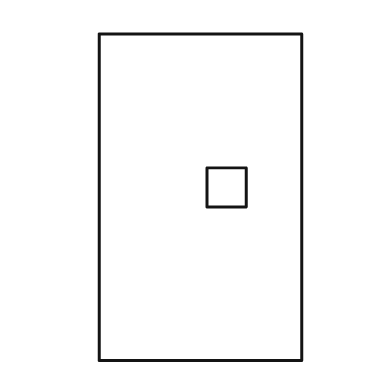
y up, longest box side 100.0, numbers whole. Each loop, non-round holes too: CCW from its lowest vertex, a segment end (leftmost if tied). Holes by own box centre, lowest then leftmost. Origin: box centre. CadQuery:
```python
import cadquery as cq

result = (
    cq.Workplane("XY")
    .moveTo(-31.0, -50.0)
    .lineTo(31.0, -50.0)
    .lineTo(31.0, 50.0)
    .lineTo(-31.0, 50.0)
    .close()
    .moveTo(2.0, -3.0)
    .lineTo(14.0, -3.0)
    .lineTo(14.0, 9.0)
    .lineTo(2.0, 9.0)
    .close()
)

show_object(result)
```